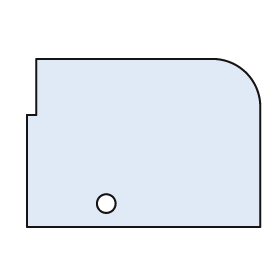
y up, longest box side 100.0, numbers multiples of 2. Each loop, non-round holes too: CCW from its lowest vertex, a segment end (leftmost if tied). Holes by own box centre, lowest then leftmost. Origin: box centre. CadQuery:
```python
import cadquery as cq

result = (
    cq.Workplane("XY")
    .moveTo(-50.0, -36.0)
    .lineTo(50.0, -36.0)
    .lineTo(50.0, 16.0)
    .threePointArc((44.0, 30.0), (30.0, 36.0))
    .lineTo(-46.0, 36.0)
    .lineTo(-46.0, 12.0)
    .lineTo(-50.0, 12.0)
    .close()
    .moveTo(-16.0, -26.0)
    .circle(4.0)
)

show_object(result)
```